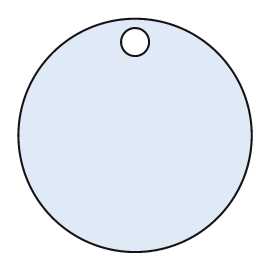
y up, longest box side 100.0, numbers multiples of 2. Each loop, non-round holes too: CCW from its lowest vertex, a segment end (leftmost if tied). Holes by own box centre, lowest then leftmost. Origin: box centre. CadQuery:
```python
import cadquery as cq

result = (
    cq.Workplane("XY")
    .moveTo(0.0, 0.0)
    .circle(50.0)
    .moveTo(0.0, 40.0)
    .circle(6.0)
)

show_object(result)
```